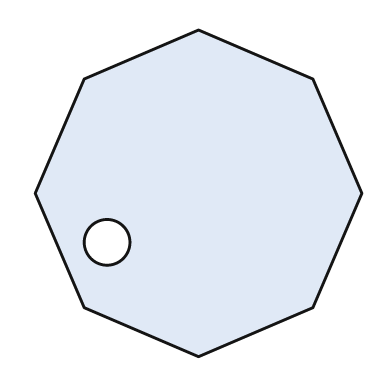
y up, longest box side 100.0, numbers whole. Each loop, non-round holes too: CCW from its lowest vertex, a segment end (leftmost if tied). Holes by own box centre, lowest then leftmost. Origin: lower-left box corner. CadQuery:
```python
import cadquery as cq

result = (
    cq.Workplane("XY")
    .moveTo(50.0, 0.0)
    .lineTo(85.0, 15.0)
    .lineTo(100.0, 50.0)
    .lineTo(85.0, 85.0)
    .lineTo(50.0, 100.0)
    .lineTo(15.0, 85.0)
    .lineTo(0.0, 50.0)
    .lineTo(15.0, 15.0)
    .close()
    .moveTo(22.0, 35.0)
    .circle(7.0)
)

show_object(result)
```